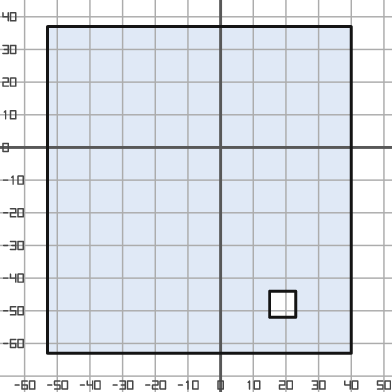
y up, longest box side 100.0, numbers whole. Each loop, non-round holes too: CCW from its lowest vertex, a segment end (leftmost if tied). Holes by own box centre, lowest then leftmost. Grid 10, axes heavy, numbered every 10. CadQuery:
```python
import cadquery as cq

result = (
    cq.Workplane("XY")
    .moveTo(-53.0, -63.0)
    .lineTo(40.0, -63.0)
    .lineTo(40.0, 37.0)
    .lineTo(-53.0, 37.0)
    .close()
    .moveTo(15.0, -52.0)
    .lineTo(23.0, -52.0)
    .lineTo(23.0, -44.0)
    .lineTo(15.0, -44.0)
    .close()
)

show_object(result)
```